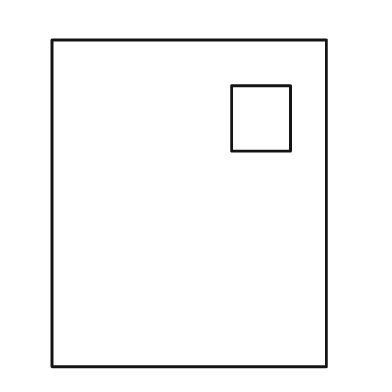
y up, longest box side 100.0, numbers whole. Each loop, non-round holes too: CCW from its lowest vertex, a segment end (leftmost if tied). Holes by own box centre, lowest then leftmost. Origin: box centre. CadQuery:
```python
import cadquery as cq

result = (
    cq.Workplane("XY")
    .moveTo(-42.0, -50.0)
    .lineTo(42.0, -50.0)
    .lineTo(42.0, 50.0)
    .lineTo(-42.0, 50.0)
    .close()
    .moveTo(13.0, 16.0)
    .lineTo(31.0, 16.0)
    .lineTo(31.0, 36.0)
    .lineTo(13.0, 36.0)
    .close()
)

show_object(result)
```